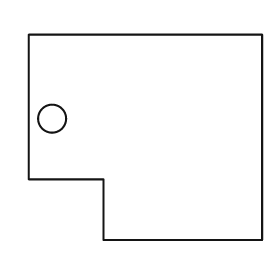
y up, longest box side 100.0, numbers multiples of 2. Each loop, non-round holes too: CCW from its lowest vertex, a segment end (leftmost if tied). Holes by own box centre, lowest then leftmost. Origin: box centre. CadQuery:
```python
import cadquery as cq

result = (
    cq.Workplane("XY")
    .moveTo(-18.0, -44.0)
    .lineTo(50.0, -44.0)
    .lineTo(50.0, 44.0)
    .lineTo(-50.0, 44.0)
    .lineTo(-50.0, -18.0)
    .lineTo(-18.0, -18.0)
    .close()
    .moveTo(-40.0, 8.0)
    .circle(6.0)
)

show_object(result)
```